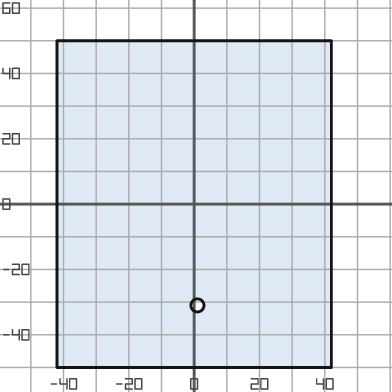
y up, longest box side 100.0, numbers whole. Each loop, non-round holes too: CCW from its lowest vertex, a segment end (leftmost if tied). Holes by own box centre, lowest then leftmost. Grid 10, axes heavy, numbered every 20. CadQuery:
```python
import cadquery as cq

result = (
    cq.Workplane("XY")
    .moveTo(-42.0, -50.0)
    .lineTo(42.0, -50.0)
    .lineTo(42.0, 50.0)
    .lineTo(-42.0, 50.0)
    .close()
    .moveTo(1.0, -31.0)
    .circle(2.0)
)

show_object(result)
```